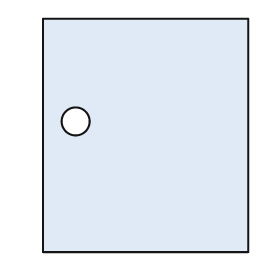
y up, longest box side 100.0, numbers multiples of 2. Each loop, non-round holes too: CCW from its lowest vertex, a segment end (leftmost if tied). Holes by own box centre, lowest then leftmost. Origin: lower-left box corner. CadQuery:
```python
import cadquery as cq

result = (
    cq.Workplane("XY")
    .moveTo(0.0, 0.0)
    .lineTo(88.0, 0.0)
    .lineTo(88.0, 100.0)
    .lineTo(0.0, 100.0)
    .close()
    .moveTo(14.0, 56.0)
    .circle(6.0)
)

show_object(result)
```